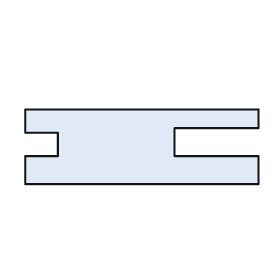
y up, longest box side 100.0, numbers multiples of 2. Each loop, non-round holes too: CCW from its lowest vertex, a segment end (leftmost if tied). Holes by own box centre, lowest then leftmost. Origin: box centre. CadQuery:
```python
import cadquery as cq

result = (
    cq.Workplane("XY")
    .moveTo(-50.0, -16.0)
    .lineTo(50.0, -16.0)
    .lineTo(50.0, -4.0)
    .lineTo(14.0, -4.0)
    .lineTo(14.0, 8.0)
    .lineTo(50.0, 8.0)
    .lineTo(50.0, 16.0)
    .lineTo(-50.0, 16.0)
    .lineTo(-50.0, 6.0)
    .lineTo(-36.0, 6.0)
    .lineTo(-36.0, -4.0)
    .lineTo(-50.0, -4.0)
    .close()
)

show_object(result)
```